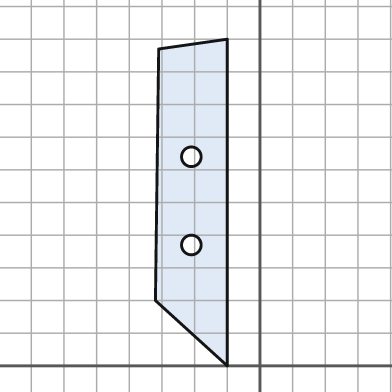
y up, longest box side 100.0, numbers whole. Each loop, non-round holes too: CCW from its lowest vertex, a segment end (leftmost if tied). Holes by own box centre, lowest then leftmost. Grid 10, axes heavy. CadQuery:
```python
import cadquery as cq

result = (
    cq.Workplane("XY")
    .moveTo(-10.0, 0.0)
    .lineTo(-10.0, 100.0)
    .lineTo(-31.0, 97.0)
    .lineTo(-32.0, 20.0)
    .close()
    .moveTo(-21.0, 37.0)
    .circle(3.0)
    .moveTo(-21.0, 64.0)
    .circle(3.0)
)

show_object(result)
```